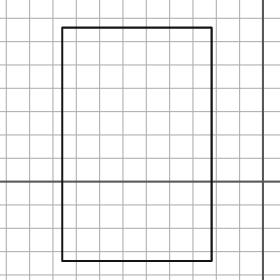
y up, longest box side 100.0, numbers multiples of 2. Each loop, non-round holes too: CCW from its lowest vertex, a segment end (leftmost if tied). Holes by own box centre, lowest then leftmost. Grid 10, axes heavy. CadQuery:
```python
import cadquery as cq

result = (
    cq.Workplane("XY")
    .moveTo(-86.0, -34.0)
    .lineTo(-22.0, -34.0)
    .lineTo(-22.0, 66.0)
    .lineTo(-86.0, 66.0)
    .close()
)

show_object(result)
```